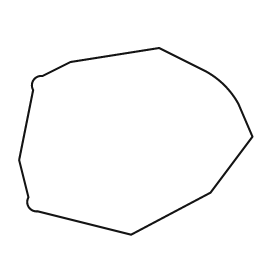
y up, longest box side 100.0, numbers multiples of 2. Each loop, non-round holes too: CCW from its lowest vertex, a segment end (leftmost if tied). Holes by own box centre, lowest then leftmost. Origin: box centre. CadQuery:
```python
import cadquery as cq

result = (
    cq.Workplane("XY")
    .moveTo(-2.0, -40.0)
    .lineTo(32.0, -22.0)
    .lineTo(50.0, 2.0)
    .lineTo(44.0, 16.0)
    .threePointArc((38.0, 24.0), (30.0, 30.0))
    .lineTo(10.0, 40.0)
    .lineTo(-28.0, 34.0)
    .lineTo(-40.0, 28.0)
    .threePointArc((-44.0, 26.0), (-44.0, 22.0))
    .lineTo(-50.0, -8.0)
    .lineTo(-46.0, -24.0)
    .threePointArc((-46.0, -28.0), (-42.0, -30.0))
    .close()
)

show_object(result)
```